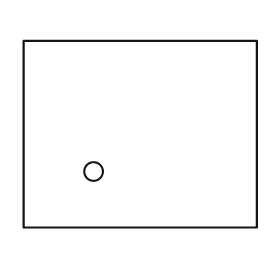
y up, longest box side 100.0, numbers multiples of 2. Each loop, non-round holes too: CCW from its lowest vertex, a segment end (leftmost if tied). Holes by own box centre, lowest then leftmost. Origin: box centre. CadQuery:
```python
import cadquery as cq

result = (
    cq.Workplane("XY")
    .moveTo(-50.0, -40.0)
    .lineTo(50.0, -40.0)
    .lineTo(50.0, 40.0)
    .lineTo(-50.0, 40.0)
    .close()
    .moveTo(-20.0, -16.0)
    .circle(4.0)
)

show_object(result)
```